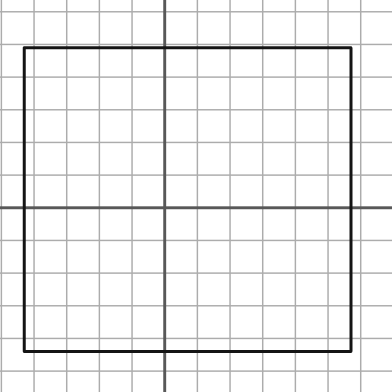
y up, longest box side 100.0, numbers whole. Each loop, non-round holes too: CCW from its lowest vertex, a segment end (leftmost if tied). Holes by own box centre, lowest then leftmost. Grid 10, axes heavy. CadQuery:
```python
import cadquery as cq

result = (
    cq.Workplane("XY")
    .moveTo(-43.0, -44.0)
    .lineTo(57.0, -44.0)
    .lineTo(57.0, 49.0)
    .lineTo(-43.0, 49.0)
    .close()
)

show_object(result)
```